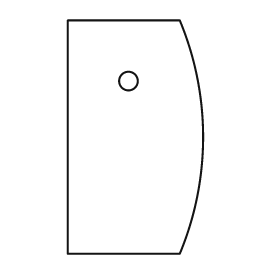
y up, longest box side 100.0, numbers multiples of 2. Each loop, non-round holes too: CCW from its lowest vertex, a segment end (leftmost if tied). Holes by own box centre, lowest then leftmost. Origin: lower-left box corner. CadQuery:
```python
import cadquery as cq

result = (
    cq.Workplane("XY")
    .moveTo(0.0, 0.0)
    .lineTo(48.0, 0.0)
    .threePointArc((58.0, 50.0), (48.0, 100.0))
    .lineTo(0.0, 100.0)
    .close()
    .moveTo(26.0, 74.0)
    .circle(4.0)
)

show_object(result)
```